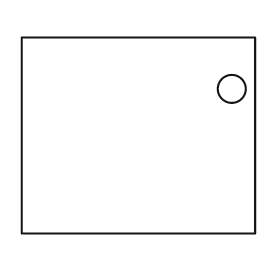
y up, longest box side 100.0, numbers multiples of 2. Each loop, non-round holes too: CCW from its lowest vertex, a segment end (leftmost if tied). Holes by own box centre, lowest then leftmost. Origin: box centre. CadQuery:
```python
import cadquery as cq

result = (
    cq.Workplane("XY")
    .moveTo(-50.0, -42.0)
    .lineTo(50.0, -42.0)
    .lineTo(50.0, 42.0)
    .lineTo(-50.0, 42.0)
    .close()
    .moveTo(40.0, 20.0)
    .circle(6.0)
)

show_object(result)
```